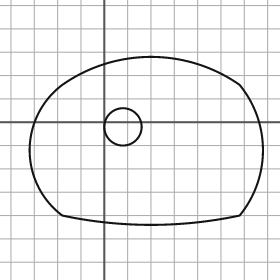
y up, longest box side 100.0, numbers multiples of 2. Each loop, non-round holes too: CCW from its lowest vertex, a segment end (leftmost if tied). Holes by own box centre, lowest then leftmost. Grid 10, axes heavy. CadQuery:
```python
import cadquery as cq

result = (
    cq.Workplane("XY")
    .moveTo(-18.0, -40.0)
    .threePointArc((20.0, -44.0), (58.0, -40.0))
    .threePointArc((68.0, -12.0), (58.0, 16.0))
    .threePointArc((20.0, 28.0), (-18.0, 16.0))
    .threePointArc((-32.0, -12.0), (-18.0, -40.0))
    .close()
    .moveTo(8.0, -2.0)
    .circle(8.0)
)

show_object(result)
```